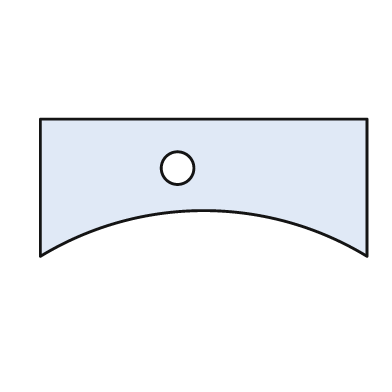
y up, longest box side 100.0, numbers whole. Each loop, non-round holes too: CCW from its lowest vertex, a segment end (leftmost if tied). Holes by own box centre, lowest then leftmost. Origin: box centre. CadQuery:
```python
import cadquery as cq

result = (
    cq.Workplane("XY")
    .moveTo(-50.0, -21.0)
    .threePointArc((0.0, -7.0), (50.0, -21.0))
    .lineTo(50.0, 21.0)
    .lineTo(-50.0, 21.0)
    .close()
    .moveTo(-8.0, 6.0)
    .circle(5.0)
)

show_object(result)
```